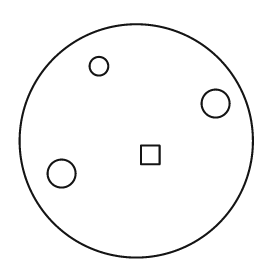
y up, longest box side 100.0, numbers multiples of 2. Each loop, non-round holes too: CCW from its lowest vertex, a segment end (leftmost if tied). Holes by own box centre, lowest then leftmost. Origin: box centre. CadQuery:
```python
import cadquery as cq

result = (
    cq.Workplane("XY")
    .moveTo(0.0, 0.0)
    .circle(50.0)
    .moveTo(-32.0, -14.0)
    .circle(6.0)
    .moveTo(2.0, -10.0)
    .lineTo(10.0, -10.0)
    .lineTo(10.0, -2.0)
    .lineTo(2.0, -2.0)
    .close()
    .moveTo(34.0, 16.0)
    .circle(6.0)
    .moveTo(-16.0, 32.0)
    .circle(4.0)
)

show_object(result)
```